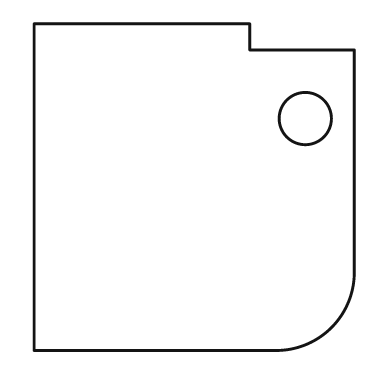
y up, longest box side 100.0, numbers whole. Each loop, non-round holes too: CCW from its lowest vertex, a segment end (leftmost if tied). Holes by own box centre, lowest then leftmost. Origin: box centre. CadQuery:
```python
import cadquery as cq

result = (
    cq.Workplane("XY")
    .moveTo(-49.0, -50.0)
    .lineTo(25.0, -50.0)
    .threePointArc((42.0, -43.0), (49.0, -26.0))
    .lineTo(49.0, 42.0)
    .lineTo(17.0, 42.0)
    .lineTo(17.0, 50.0)
    .lineTo(-49.0, 50.0)
    .close()
    .moveTo(34.0, 21.0)
    .circle(8.0)
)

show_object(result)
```